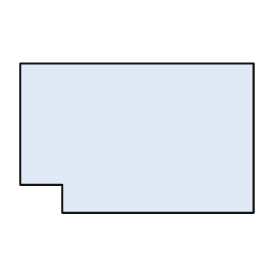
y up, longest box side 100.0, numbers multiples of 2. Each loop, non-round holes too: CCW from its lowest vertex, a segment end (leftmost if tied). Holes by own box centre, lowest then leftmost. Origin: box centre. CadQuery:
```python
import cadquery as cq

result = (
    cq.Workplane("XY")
    .moveTo(-32.0, -32.0)
    .lineTo(50.0, -32.0)
    .lineTo(50.0, 32.0)
    .lineTo(-50.0, 32.0)
    .lineTo(-50.0, -20.0)
    .lineTo(-32.0, -20.0)
    .close()
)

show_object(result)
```